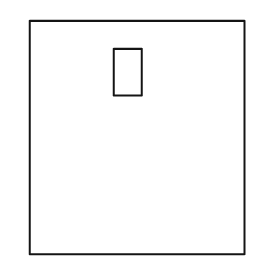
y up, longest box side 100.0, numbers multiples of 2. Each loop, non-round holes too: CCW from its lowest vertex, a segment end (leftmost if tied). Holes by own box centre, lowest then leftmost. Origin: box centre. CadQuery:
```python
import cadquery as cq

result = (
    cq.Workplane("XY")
    .moveTo(-46.0, -50.0)
    .lineTo(46.0, -50.0)
    .lineTo(46.0, 50.0)
    .lineTo(-46.0, 50.0)
    .close()
    .moveTo(-10.0, 18.0)
    .lineTo(2.0, 18.0)
    .lineTo(2.0, 38.0)
    .lineTo(-10.0, 38.0)
    .close()
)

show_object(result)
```